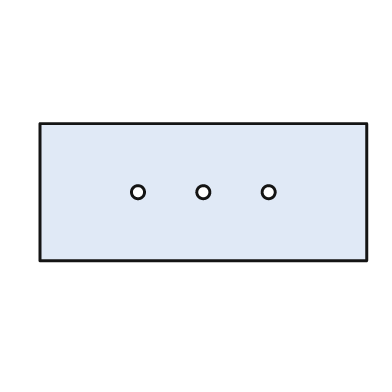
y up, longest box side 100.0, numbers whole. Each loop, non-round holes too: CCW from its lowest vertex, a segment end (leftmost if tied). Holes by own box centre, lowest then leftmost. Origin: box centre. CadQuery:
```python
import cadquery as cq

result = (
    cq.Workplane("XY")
    .moveTo(-50.0, -21.0)
    .lineTo(50.0, -21.0)
    .lineTo(50.0, 21.0)
    .lineTo(-50.0, 21.0)
    .close()
    .moveTo(-20.0, 0.0)
    .circle(2.0)
    .moveTo(0.0, 0.0)
    .circle(2.0)
    .moveTo(20.0, 0.0)
    .circle(2.0)
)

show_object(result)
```